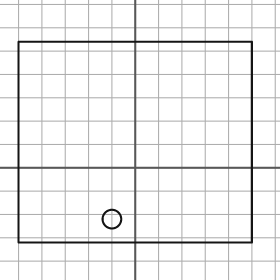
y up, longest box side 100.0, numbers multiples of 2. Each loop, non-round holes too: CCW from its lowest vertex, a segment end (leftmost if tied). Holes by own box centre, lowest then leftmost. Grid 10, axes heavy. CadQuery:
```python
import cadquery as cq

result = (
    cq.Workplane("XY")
    .moveTo(-50.0, -32.0)
    .lineTo(50.0, -32.0)
    .lineTo(50.0, 54.0)
    .lineTo(-50.0, 54.0)
    .close()
    .moveTo(-10.0, -22.0)
    .circle(4.0)
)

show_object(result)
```